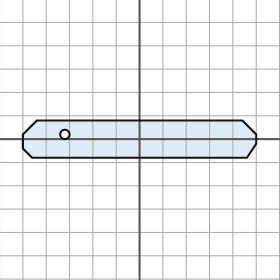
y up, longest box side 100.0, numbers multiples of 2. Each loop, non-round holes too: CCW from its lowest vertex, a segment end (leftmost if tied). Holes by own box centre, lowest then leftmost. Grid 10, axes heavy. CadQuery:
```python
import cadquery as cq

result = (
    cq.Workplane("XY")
    .moveTo(-46.0, -8.0)
    .lineTo(46.0, -8.0)
    .lineTo(50.0, -2.0)
    .lineTo(50.0, 2.0)
    .lineTo(44.0, 8.0)
    .lineTo(-44.0, 8.0)
    .lineTo(-50.0, 2.0)
    .lineTo(-50.0, -4.0)
    .close()
    .moveTo(-32.0, 2.0)
    .circle(2.0)
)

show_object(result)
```